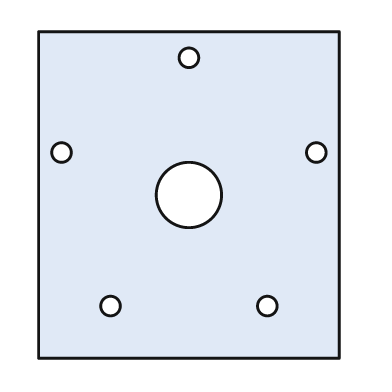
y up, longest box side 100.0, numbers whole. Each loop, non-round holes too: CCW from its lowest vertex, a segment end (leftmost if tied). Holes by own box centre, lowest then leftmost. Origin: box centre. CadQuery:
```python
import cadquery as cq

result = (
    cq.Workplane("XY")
    .moveTo(-46.0, -50.0)
    .lineTo(46.0, -50.0)
    .lineTo(46.0, 50.0)
    .lineTo(-46.0, 50.0)
    .close()
    .moveTo(-24.0, -34.0)
    .circle(3.0)
    .moveTo(24.0, -34.0)
    .circle(3.0)
    .moveTo(0.0, 0.0)
    .circle(10.0)
    .moveTo(-39.0, 13.0)
    .circle(3.0)
    .moveTo(39.0, 13.0)
    .circle(3.0)
    .moveTo(0.0, 42.0)
    .circle(3.0)
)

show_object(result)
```